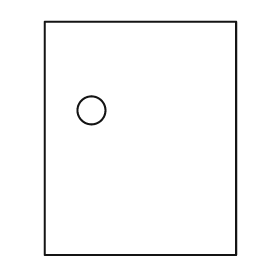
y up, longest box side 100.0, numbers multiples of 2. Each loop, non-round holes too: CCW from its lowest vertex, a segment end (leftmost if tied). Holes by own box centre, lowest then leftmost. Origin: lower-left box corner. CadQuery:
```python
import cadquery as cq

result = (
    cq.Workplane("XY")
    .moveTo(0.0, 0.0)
    .lineTo(82.0, 0.0)
    .lineTo(82.0, 100.0)
    .lineTo(0.0, 100.0)
    .close()
    .moveTo(20.0, 62.0)
    .circle(6.0)
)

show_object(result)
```